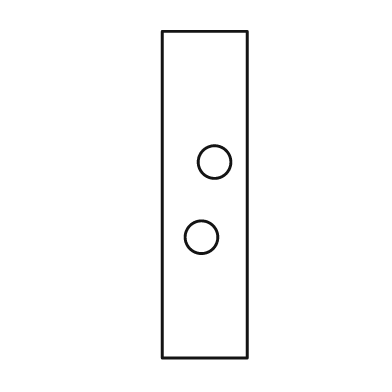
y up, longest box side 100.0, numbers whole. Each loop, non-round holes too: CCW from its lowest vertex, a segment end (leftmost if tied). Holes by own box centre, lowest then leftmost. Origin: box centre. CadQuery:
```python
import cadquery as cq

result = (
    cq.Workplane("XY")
    .moveTo(-13.0, -50.0)
    .lineTo(13.0, -50.0)
    .lineTo(13.0, 50.0)
    .lineTo(-13.0, 50.0)
    .close()
    .moveTo(-1.0, -13.0)
    .circle(5.0)
    .moveTo(3.0, 10.0)
    .circle(5.0)
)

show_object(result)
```